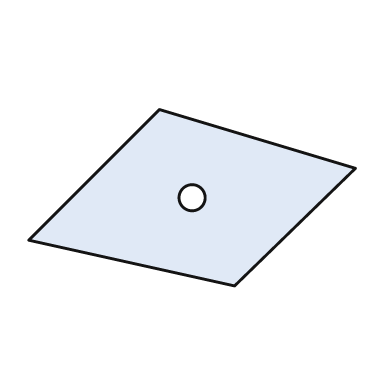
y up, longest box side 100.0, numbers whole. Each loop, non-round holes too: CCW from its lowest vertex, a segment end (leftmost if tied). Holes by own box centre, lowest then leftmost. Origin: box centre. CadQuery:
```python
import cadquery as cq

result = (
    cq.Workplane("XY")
    .moveTo(13.0, -27.0)
    .lineTo(50.0, 9.0)
    .lineTo(-10.0, 27.0)
    .lineTo(-50.0, -13.0)
    .close()
    .moveTo(0.0, 0.0)
    .circle(4.0)
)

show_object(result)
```